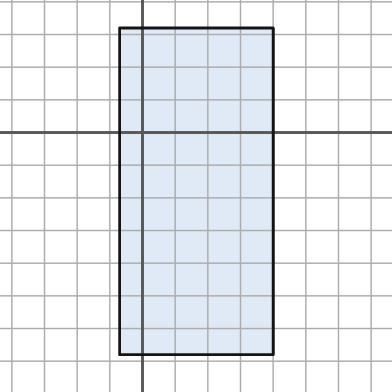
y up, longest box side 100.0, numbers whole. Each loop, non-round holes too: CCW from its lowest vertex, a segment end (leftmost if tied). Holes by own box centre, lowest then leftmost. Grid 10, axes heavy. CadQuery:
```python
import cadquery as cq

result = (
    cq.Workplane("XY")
    .moveTo(-7.0, -68.0)
    .lineTo(40.0, -68.0)
    .lineTo(40.0, 32.0)
    .lineTo(-7.0, 32.0)
    .close()
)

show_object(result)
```